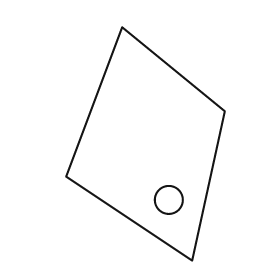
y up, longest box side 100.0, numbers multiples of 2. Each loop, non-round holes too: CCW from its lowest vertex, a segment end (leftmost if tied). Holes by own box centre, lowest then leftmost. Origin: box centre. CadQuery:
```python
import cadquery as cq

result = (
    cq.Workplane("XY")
    .moveTo(20.0, -50.0)
    .lineTo(34.0, 14.0)
    .lineTo(-10.0, 50.0)
    .lineTo(-34.0, -14.0)
    .close()
    .moveTo(10.0, -24.0)
    .circle(6.0)
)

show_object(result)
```